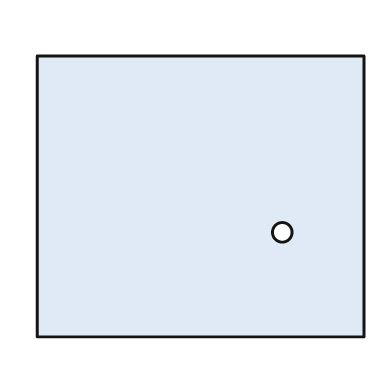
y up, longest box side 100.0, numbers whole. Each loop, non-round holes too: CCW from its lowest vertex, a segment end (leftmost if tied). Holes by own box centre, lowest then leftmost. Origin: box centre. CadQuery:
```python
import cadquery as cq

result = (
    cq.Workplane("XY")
    .moveTo(-50.0, -43.0)
    .lineTo(50.0, -43.0)
    .lineTo(50.0, 43.0)
    .lineTo(-50.0, 43.0)
    .close()
    .moveTo(25.0, -11.0)
    .circle(3.0)
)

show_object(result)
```